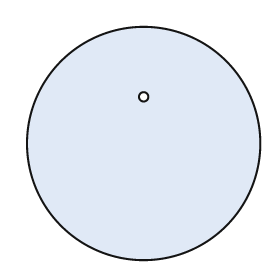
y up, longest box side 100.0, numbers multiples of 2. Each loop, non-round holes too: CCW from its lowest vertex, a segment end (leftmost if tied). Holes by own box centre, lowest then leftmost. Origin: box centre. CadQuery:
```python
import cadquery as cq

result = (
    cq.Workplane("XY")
    .moveTo(0.0, 0.0)
    .circle(50.0)
    .moveTo(0.0, 20.0)
    .circle(2.0)
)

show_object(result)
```